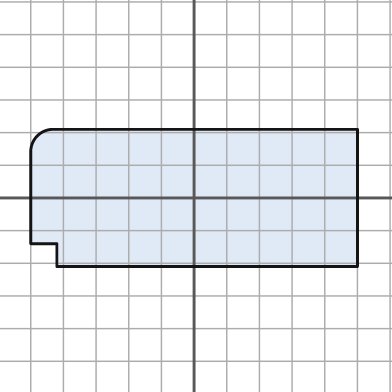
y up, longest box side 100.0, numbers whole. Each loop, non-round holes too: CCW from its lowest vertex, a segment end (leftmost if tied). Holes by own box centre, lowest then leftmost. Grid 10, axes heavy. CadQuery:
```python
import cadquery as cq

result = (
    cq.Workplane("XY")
    .moveTo(-42.0, -21.0)
    .lineTo(50.0, -21.0)
    .lineTo(50.0, 21.0)
    .lineTo(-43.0, 21.0)
    .threePointArc((-48.0, 19.0), (-50.0, 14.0))
    .lineTo(-50.0, -14.0)
    .lineTo(-42.0, -14.0)
    .close()
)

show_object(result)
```